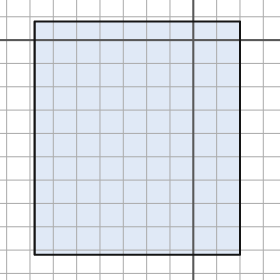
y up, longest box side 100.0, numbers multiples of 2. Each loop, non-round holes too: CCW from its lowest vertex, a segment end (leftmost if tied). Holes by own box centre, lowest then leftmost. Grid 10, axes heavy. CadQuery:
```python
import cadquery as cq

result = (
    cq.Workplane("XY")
    .moveTo(-68.0, -92.0)
    .lineTo(20.0, -92.0)
    .lineTo(20.0, 8.0)
    .lineTo(-68.0, 8.0)
    .close()
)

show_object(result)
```